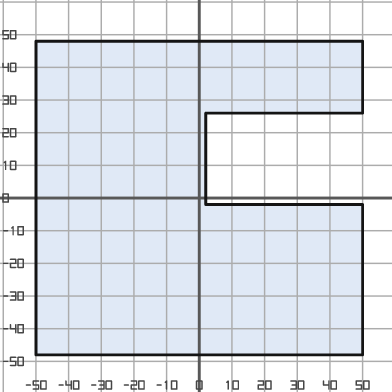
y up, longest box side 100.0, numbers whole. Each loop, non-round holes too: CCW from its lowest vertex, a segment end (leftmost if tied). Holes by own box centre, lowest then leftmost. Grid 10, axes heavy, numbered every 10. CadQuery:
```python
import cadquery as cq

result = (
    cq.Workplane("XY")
    .moveTo(-50.0, -48.0)
    .lineTo(50.0, -48.0)
    .lineTo(50.0, -2.0)
    .lineTo(2.0, -2.0)
    .lineTo(2.0, 26.0)
    .lineTo(50.0, 26.0)
    .lineTo(50.0, 48.0)
    .lineTo(-50.0, 48.0)
    .close()
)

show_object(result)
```